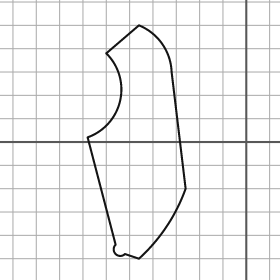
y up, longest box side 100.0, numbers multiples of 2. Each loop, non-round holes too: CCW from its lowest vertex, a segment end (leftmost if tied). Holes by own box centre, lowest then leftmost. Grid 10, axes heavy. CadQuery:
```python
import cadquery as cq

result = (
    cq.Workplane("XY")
    .moveTo(-46.0, -50.0)
    .threePointArc((-34.0, -36.0), (-26.0, -20.0))
    .lineTo(-32.0, 30.0)
    .threePointArc((-36.0, 42.0), (-46.0, 50.0))
    .lineTo(-60.0, 38.0)
    .threePointArc((-54.0, 18.0), (-68.0, 2.0))
    .lineTo(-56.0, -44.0)
    .threePointArc((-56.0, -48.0), (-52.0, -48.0))
    .close()
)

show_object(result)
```